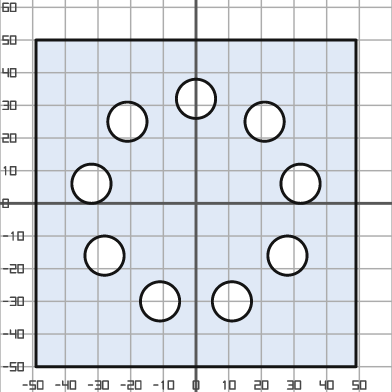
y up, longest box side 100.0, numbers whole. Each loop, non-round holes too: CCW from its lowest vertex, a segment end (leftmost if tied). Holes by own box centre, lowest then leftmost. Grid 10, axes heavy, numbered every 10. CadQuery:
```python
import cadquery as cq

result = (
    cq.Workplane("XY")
    .moveTo(-49.0, -50.0)
    .lineTo(49.0, -50.0)
    .lineTo(49.0, 50.0)
    .lineTo(-49.0, 50.0)
    .close()
    .moveTo(-11.0, -30.0)
    .circle(6.0)
    .moveTo(11.0, -30.0)
    .circle(6.0)
    .moveTo(-28.0, -16.0)
    .circle(6.0)
    .moveTo(28.0, -16.0)
    .circle(6.0)
    .moveTo(-32.0, 6.0)
    .circle(6.0)
    .moveTo(32.0, 6.0)
    .circle(6.0)
    .moveTo(-21.0, 25.0)
    .circle(6.0)
    .moveTo(21.0, 25.0)
    .circle(6.0)
    .moveTo(0.0, 32.0)
    .circle(6.0)
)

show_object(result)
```